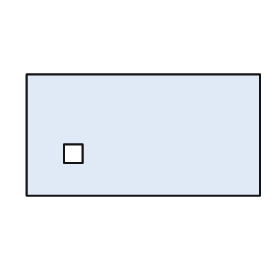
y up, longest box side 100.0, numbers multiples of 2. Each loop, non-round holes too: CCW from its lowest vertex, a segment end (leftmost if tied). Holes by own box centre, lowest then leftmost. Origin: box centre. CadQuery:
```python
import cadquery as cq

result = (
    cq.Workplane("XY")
    .moveTo(-50.0, -26.0)
    .lineTo(50.0, -26.0)
    .lineTo(50.0, 26.0)
    .lineTo(-50.0, 26.0)
    .close()
    .moveTo(-34.0, -12.0)
    .lineTo(-26.0, -12.0)
    .lineTo(-26.0, -4.0)
    .lineTo(-34.0, -4.0)
    .close()
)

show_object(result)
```